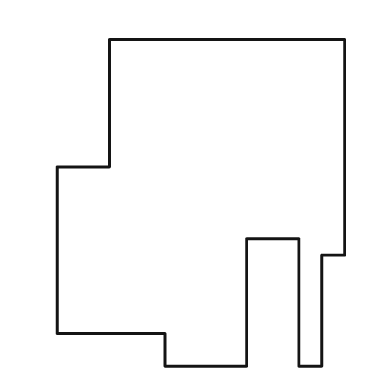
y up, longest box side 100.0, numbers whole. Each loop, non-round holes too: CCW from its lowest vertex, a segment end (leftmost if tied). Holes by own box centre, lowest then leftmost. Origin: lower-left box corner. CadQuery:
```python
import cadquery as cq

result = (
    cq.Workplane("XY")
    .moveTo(33.0, 0.0)
    .lineTo(58.0, 0.0)
    .lineTo(58.0, 39.0)
    .lineTo(74.0, 39.0)
    .lineTo(74.0, 0.0)
    .lineTo(81.0, 0.0)
    .lineTo(81.0, 34.0)
    .lineTo(88.0, 34.0)
    .lineTo(88.0, 100.0)
    .lineTo(16.0, 100.0)
    .lineTo(16.0, 61.0)
    .lineTo(0.0, 61.0)
    .lineTo(0.0, 10.0)
    .lineTo(33.0, 10.0)
    .close()
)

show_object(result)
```